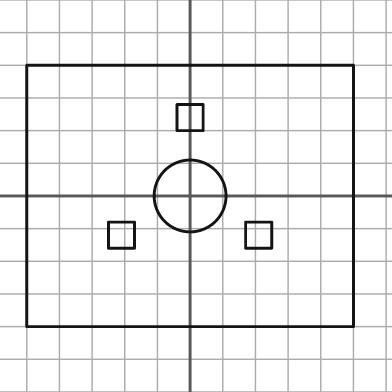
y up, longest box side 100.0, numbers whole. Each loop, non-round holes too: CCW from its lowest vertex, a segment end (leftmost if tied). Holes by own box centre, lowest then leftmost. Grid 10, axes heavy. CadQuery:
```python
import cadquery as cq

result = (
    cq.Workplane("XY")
    .moveTo(-50.0, -40.0)
    .lineTo(50.0, -40.0)
    .lineTo(50.0, 40.0)
    .lineTo(-50.0, 40.0)
    .close()
    .moveTo(-25.0, -16.0)
    .lineTo(-17.0, -16.0)
    .lineTo(-17.0, -8.0)
    .lineTo(-25.0, -8.0)
    .close()
    .moveTo(17.0, -16.0)
    .lineTo(25.0, -16.0)
    .lineTo(25.0, -8.0)
    .lineTo(17.0, -8.0)
    .close()
    .moveTo(0.0, 0.0)
    .circle(11.0)
    .moveTo(-4.0, 20.0)
    .lineTo(4.0, 20.0)
    .lineTo(4.0, 28.0)
    .lineTo(-4.0, 28.0)
    .close()
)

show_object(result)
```